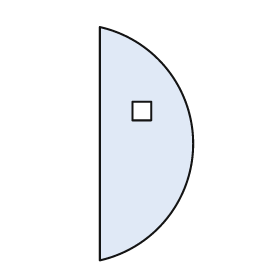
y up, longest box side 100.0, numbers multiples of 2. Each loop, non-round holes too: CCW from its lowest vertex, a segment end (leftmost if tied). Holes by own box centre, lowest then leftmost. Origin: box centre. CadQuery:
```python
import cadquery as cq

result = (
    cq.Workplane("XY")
    .moveTo(-20.0, -50.0)
    .threePointArc((20.0, 0.0), (-20.0, 50.0))
    .close()
    .moveTo(-6.0, 10.0)
    .lineTo(2.0, 10.0)
    .lineTo(2.0, 18.0)
    .lineTo(-6.0, 18.0)
    .close()
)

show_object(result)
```